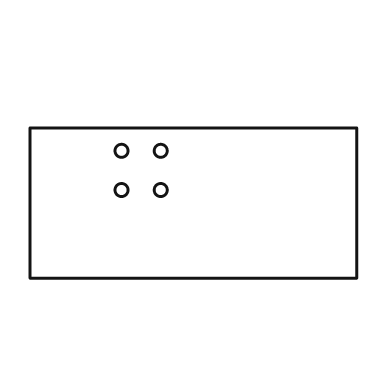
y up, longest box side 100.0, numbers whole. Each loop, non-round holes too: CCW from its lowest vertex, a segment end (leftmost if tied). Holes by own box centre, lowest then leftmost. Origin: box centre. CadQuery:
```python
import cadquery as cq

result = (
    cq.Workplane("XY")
    .moveTo(-50.0, -23.0)
    .lineTo(50.0, -23.0)
    .lineTo(50.0, 23.0)
    .lineTo(-50.0, 23.0)
    .close()
    .moveTo(-22.0, 4.0)
    .circle(2.0)
    .moveTo(-10.0, 4.0)
    .circle(2.0)
    .moveTo(-22.0, 16.0)
    .circle(2.0)
    .moveTo(-10.0, 16.0)
    .circle(2.0)
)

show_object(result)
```